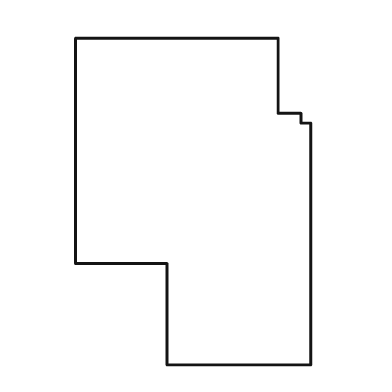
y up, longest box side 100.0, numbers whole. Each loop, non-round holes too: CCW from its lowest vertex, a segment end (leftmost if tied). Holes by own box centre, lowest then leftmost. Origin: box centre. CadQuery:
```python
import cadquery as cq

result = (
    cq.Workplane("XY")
    .moveTo(-8.0, -50.0)
    .lineTo(36.0, -50.0)
    .lineTo(36.0, 24.0)
    .lineTo(33.0, 24.0)
    .lineTo(33.0, 27.0)
    .lineTo(26.0, 27.0)
    .lineTo(26.0, 50.0)
    .lineTo(-36.0, 50.0)
    .lineTo(-36.0, -19.0)
    .lineTo(-8.0, -19.0)
    .close()
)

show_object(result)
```